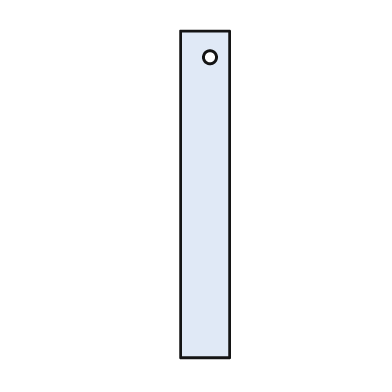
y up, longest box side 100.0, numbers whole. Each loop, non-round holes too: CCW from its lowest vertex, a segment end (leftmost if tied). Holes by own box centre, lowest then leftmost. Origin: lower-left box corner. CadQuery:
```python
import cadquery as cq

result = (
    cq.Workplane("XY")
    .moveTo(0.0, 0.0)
    .lineTo(15.0, 0.0)
    .lineTo(15.0, 100.0)
    .lineTo(0.0, 100.0)
    .close()
    .moveTo(9.0, 92.0)
    .circle(2.0)
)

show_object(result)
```